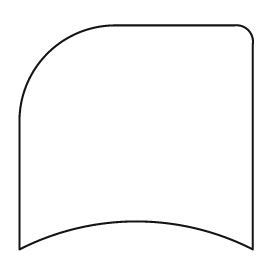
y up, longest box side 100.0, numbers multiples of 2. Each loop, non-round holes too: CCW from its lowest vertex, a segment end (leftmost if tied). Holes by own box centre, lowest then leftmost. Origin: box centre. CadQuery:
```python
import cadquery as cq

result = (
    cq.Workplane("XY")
    .moveTo(-50.0, -48.0)
    .threePointArc((0.0, -36.0), (50.0, -48.0))
    .lineTo(50.0, 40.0)
    .threePointArc((48.0, 46.0), (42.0, 48.0))
    .lineTo(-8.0, 48.0)
    .threePointArc((-38.0, 36.0), (-50.0, 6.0))
    .close()
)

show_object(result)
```